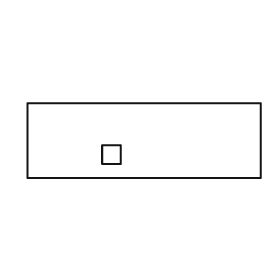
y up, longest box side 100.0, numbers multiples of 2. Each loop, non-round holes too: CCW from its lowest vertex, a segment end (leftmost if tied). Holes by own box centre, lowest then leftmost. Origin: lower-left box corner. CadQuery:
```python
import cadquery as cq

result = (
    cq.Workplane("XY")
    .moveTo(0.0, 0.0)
    .lineTo(100.0, 0.0)
    .lineTo(100.0, 32.0)
    .lineTo(0.0, 32.0)
    .close()
    .moveTo(32.0, 6.0)
    .lineTo(40.0, 6.0)
    .lineTo(40.0, 14.0)
    .lineTo(32.0, 14.0)
    .close()
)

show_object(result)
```